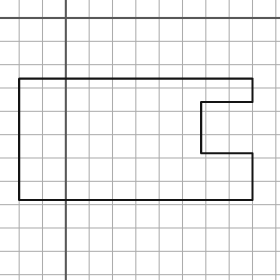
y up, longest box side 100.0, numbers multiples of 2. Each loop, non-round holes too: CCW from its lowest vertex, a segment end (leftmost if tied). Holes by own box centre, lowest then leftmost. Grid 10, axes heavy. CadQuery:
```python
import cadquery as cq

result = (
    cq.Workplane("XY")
    .moveTo(-20.0, -78.0)
    .lineTo(80.0, -78.0)
    .lineTo(80.0, -58.0)
    .lineTo(58.0, -58.0)
    .lineTo(58.0, -36.0)
    .lineTo(80.0, -36.0)
    .lineTo(80.0, -26.0)
    .lineTo(-20.0, -26.0)
    .close()
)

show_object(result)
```